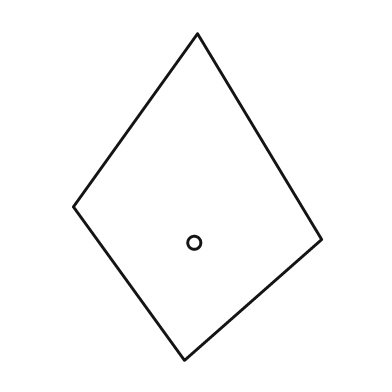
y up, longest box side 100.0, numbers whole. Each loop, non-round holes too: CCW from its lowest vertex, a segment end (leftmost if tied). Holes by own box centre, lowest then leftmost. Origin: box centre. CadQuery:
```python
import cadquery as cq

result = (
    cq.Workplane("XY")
    .moveTo(-4.0, -50.0)
    .lineTo(38.0, -13.0)
    .lineTo(0.0, 50.0)
    .lineTo(-38.0, -3.0)
    .close()
    .moveTo(-1.0, -14.0)
    .circle(2.0)
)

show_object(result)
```